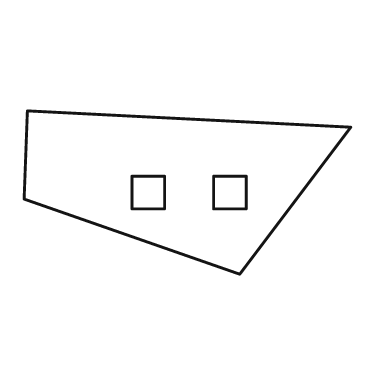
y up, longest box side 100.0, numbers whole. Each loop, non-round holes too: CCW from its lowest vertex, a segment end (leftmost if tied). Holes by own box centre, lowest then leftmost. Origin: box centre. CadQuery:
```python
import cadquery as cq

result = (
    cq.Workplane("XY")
    .moveTo(16.0, -25.0)
    .lineTo(50.0, 20.0)
    .lineTo(-49.0, 25.0)
    .lineTo(-50.0, -2.0)
    .close()
    .moveTo(-17.0, -5.0)
    .lineTo(-7.0, -5.0)
    .lineTo(-7.0, 5.0)
    .lineTo(-17.0, 5.0)
    .close()
    .moveTo(8.0, -5.0)
    .lineTo(18.0, -5.0)
    .lineTo(18.0, 5.0)
    .lineTo(8.0, 5.0)
    .close()
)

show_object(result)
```